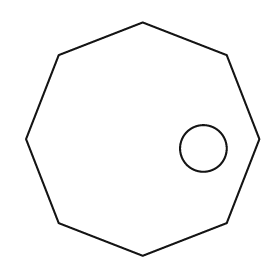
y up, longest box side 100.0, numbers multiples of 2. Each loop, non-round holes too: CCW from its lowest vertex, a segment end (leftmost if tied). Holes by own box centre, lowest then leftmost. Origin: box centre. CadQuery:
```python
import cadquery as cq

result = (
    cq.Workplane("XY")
    .moveTo(0.0, -50.0)
    .lineTo(36.0, -36.0)
    .lineTo(50.0, 0.0)
    .lineTo(36.0, 36.0)
    .lineTo(0.0, 50.0)
    .lineTo(-36.0, 36.0)
    .lineTo(-50.0, 0.0)
    .lineTo(-36.0, -36.0)
    .close()
    .moveTo(26.0, -4.0)
    .circle(10.0)
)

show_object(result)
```